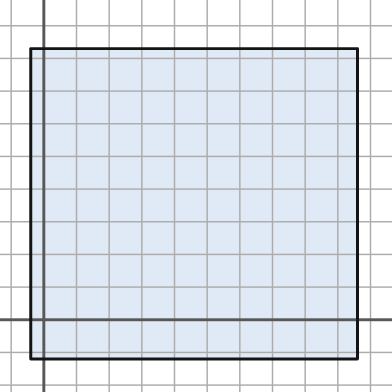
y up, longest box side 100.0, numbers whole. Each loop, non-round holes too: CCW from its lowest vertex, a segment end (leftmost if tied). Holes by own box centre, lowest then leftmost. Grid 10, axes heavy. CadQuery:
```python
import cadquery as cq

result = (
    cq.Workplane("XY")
    .moveTo(-4.0, -12.0)
    .lineTo(96.0, -12.0)
    .lineTo(96.0, 83.0)
    .lineTo(-4.0, 83.0)
    .close()
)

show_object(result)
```